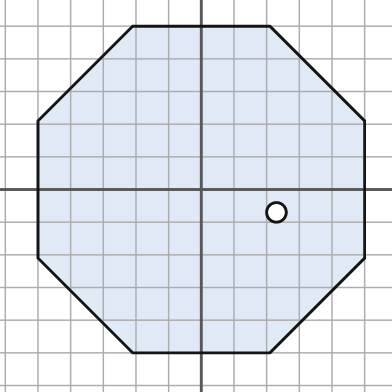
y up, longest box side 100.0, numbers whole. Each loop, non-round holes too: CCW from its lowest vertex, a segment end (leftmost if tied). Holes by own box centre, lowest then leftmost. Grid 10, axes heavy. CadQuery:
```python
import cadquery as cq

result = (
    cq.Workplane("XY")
    .moveTo(-21.0, -50.0)
    .lineTo(21.0, -50.0)
    .lineTo(50.0, -21.0)
    .lineTo(50.0, 21.0)
    .lineTo(21.0, 50.0)
    .lineTo(-21.0, 50.0)
    .lineTo(-50.0, 21.0)
    .lineTo(-50.0, -21.0)
    .close()
    .moveTo(23.0, -7.0)
    .circle(3.0)
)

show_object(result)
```